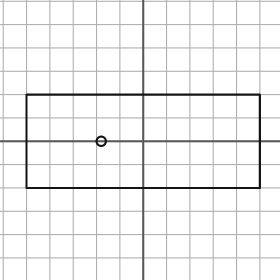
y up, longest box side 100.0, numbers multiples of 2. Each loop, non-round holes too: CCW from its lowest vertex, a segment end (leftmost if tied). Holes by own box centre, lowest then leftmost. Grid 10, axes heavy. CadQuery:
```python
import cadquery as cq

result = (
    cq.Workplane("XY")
    .moveTo(-50.0, -20.0)
    .lineTo(50.0, -20.0)
    .lineTo(50.0, 20.0)
    .lineTo(-50.0, 20.0)
    .close()
    .moveTo(-18.0, 0.0)
    .circle(2.0)
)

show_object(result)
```